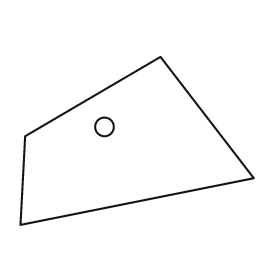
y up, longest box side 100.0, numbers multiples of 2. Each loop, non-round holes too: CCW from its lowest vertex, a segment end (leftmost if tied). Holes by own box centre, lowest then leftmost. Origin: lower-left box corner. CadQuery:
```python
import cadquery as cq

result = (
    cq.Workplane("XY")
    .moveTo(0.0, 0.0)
    .lineTo(100.0, 20.0)
    .lineTo(60.0, 72.0)
    .lineTo(2.0, 38.0)
    .close()
    .moveTo(36.0, 42.0)
    .circle(4.0)
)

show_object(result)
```